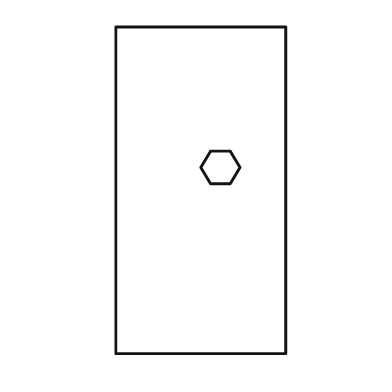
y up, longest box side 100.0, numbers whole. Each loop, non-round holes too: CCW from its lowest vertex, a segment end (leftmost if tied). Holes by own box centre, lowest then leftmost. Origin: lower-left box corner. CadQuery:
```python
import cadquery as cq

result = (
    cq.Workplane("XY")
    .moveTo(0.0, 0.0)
    .lineTo(52.0, 0.0)
    .lineTo(52.0, 100.0)
    .lineTo(0.0, 100.0)
    .close()
    .moveTo(29.0, 52.0)
    .lineTo(35.0, 52.0)
    .lineTo(38.0, 57.0)
    .lineTo(35.0, 62.0)
    .lineTo(29.0, 62.0)
    .lineTo(26.0, 57.0)
    .close()
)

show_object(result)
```